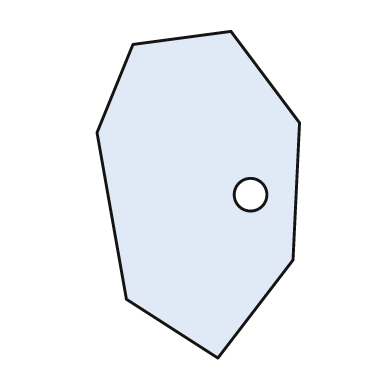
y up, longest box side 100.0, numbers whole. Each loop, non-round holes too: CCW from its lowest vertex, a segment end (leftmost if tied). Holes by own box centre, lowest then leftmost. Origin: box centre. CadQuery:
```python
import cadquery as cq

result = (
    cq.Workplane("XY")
    .moveTo(6.0, -50.0)
    .lineTo(29.0, -20.0)
    .lineTo(31.0, 22.0)
    .lineTo(10.0, 50.0)
    .lineTo(-20.0, 46.0)
    .lineTo(-31.0, 19.0)
    .lineTo(-22.0, -32.0)
    .close()
    .moveTo(16.0, 0.0)
    .circle(5.0)
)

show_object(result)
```